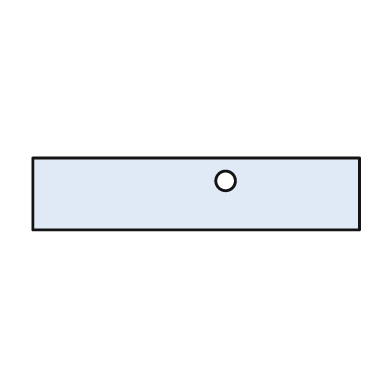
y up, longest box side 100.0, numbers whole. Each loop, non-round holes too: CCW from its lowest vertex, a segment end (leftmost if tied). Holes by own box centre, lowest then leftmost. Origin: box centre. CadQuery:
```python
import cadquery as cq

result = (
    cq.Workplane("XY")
    .moveTo(-50.0, -11.0)
    .lineTo(50.0, -11.0)
    .lineTo(50.0, 11.0)
    .lineTo(-50.0, 11.0)
    .close()
    .moveTo(9.0, 4.0)
    .circle(3.0)
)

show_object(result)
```